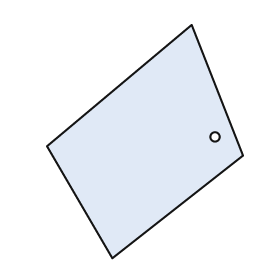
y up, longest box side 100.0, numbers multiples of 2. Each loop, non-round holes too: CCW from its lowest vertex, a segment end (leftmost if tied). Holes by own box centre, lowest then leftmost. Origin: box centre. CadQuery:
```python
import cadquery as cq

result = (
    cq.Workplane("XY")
    .moveTo(-14.0, -50.0)
    .lineTo(42.0, -6.0)
    .lineTo(20.0, 50.0)
    .lineTo(-42.0, -2.0)
    .close()
    .moveTo(30.0, 2.0)
    .circle(2.0)
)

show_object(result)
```